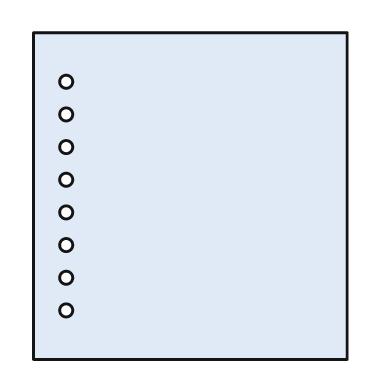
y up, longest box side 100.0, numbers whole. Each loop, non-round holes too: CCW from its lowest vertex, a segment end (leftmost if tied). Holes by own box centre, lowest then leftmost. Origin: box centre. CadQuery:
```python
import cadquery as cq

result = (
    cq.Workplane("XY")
    .moveTo(-48.0, -50.0)
    .lineTo(48.0, -50.0)
    .lineTo(48.0, 50.0)
    .lineTo(-48.0, 50.0)
    .close()
    .moveTo(-38.0, -35.0)
    .circle(2.0)
    .moveTo(-38.0, -25.0)
    .circle(2.0)
    .moveTo(-38.0, -15.0)
    .circle(2.0)
    .moveTo(-38.0, -5.0)
    .circle(2.0)
    .moveTo(-38.0, 5.0)
    .circle(2.0)
    .moveTo(-38.0, 15.0)
    .circle(2.0)
    .moveTo(-38.0, 25.0)
    .circle(2.0)
    .moveTo(-38.0, 35.0)
    .circle(2.0)
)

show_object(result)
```